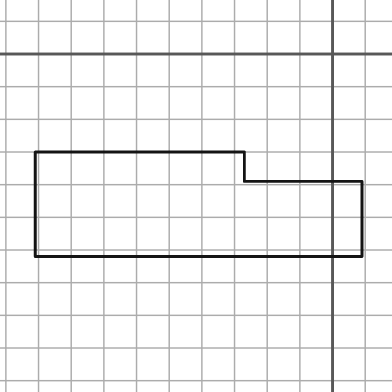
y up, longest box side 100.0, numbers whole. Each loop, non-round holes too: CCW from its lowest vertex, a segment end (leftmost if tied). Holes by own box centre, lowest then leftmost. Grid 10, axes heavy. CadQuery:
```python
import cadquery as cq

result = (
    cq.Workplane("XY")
    .moveTo(-91.0, -62.0)
    .lineTo(9.0, -62.0)
    .lineTo(9.0, -39.0)
    .lineTo(-27.0, -39.0)
    .lineTo(-27.0, -30.0)
    .lineTo(-91.0, -30.0)
    .close()
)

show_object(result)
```